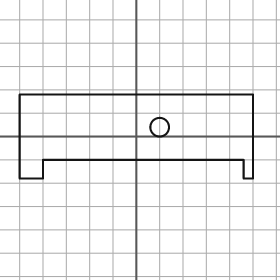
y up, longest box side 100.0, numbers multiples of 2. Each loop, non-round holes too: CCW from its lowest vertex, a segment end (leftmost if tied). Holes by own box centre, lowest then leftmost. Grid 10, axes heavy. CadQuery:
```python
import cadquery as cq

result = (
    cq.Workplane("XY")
    .moveTo(-50.0, -18.0)
    .lineTo(-40.0, -18.0)
    .lineTo(-40.0, -10.0)
    .lineTo(46.0, -10.0)
    .lineTo(46.0, -18.0)
    .lineTo(50.0, -18.0)
    .lineTo(50.0, 18.0)
    .lineTo(-50.0, 18.0)
    .close()
    .moveTo(10.0, 4.0)
    .circle(4.0)
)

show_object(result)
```